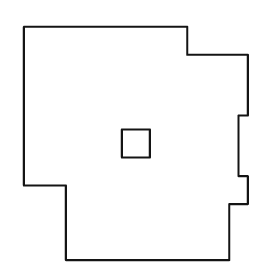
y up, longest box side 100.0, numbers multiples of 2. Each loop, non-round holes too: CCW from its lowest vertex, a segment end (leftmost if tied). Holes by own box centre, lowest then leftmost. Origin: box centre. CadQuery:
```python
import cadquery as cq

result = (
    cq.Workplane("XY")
    .moveTo(-30.0, -50.0)
    .lineTo(40.0, -50.0)
    .lineTo(40.0, -26.0)
    .lineTo(48.0, -26.0)
    .lineTo(48.0, -14.0)
    .lineTo(44.0, -14.0)
    .lineTo(44.0, 12.0)
    .lineTo(48.0, 12.0)
    .lineTo(48.0, 38.0)
    .lineTo(22.0, 38.0)
    .lineTo(22.0, 50.0)
    .lineTo(-48.0, 50.0)
    .lineTo(-48.0, -18.0)
    .lineTo(-30.0, -18.0)
    .close()
    .moveTo(-6.0, -6.0)
    .lineTo(6.0, -6.0)
    .lineTo(6.0, 6.0)
    .lineTo(-6.0, 6.0)
    .close()
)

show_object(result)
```